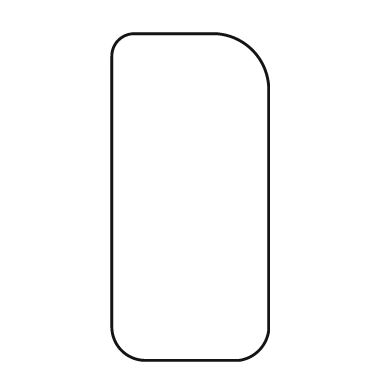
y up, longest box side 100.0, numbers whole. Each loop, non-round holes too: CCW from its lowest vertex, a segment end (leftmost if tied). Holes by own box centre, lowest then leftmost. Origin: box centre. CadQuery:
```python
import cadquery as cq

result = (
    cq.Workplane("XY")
    .moveTo(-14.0, -50.0)
    .lineTo(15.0, -50.0)
    .threePointArc((21.0, -47.0), (24.0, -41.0))
    .lineTo(24.0, 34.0)
    .threePointArc((19.0, 45.0), (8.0, 50.0))
    .lineTo(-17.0, 50.0)
    .threePointArc((-22.0, 48.0), (-24.0, 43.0))
    .lineTo(-24.0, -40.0)
    .threePointArc((-21.0, -47.0), (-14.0, -50.0))
    .close()
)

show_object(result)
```